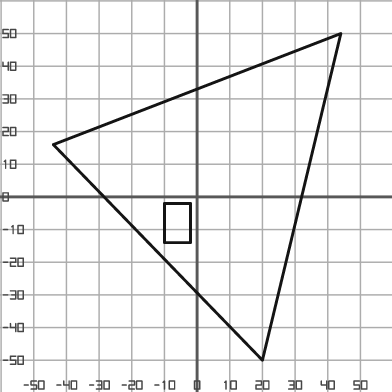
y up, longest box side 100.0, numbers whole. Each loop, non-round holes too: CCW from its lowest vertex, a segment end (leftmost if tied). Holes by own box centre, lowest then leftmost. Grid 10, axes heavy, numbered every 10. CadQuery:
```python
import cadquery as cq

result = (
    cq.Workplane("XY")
    .moveTo(20.0, -50.0)
    .lineTo(44.0, 50.0)
    .lineTo(-44.0, 16.0)
    .close()
    .moveTo(-10.0, -14.0)
    .lineTo(-2.0, -14.0)
    .lineTo(-2.0, -2.0)
    .lineTo(-10.0, -2.0)
    .close()
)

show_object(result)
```